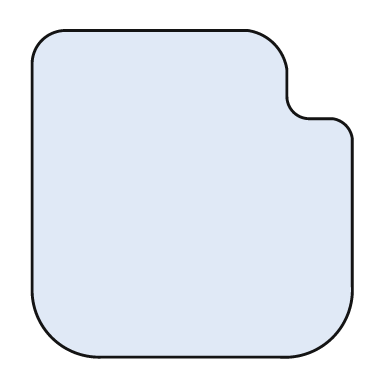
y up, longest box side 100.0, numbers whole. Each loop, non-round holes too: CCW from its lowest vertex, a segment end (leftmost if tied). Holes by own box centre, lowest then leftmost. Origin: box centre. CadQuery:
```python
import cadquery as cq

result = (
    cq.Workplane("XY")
    .moveTo(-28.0, -50.0)
    .lineTo(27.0, -50.0)
    .threePointArc((43.0, -44.0), (49.0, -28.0))
    .lineTo(49.0, 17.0)
    .threePointArc((47.0, 21.0), (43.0, 23.0))
    .lineTo(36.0, 23.0)
    .threePointArc((31.0, 25.0), (29.0, 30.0))
    .lineTo(29.0, 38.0)
    .threePointArc((25.0, 46.0), (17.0, 50.0))
    .lineTo(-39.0, 50.0)
    .threePointArc((-46.0, 47.0), (-49.0, 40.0))
    .lineTo(-49.0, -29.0)
    .threePointArc((-43.0, -44.0), (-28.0, -50.0))
    .close()
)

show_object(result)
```